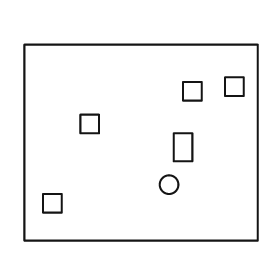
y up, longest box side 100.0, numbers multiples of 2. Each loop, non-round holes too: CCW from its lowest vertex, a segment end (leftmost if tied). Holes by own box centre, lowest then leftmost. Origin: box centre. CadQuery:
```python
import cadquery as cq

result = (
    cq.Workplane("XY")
    .moveTo(-50.0, -42.0)
    .lineTo(50.0, -42.0)
    .lineTo(50.0, 42.0)
    .lineTo(-50.0, 42.0)
    .close()
    .moveTo(-42.0, -30.0)
    .lineTo(-34.0, -30.0)
    .lineTo(-34.0, -22.0)
    .lineTo(-42.0, -22.0)
    .close()
    .moveTo(12.0, -18.0)
    .circle(4.0)
    .moveTo(14.0, -8.0)
    .lineTo(22.0, -8.0)
    .lineTo(22.0, 4.0)
    .lineTo(14.0, 4.0)
    .close()
    .moveTo(-26.0, 4.0)
    .lineTo(-18.0, 4.0)
    .lineTo(-18.0, 12.0)
    .lineTo(-26.0, 12.0)
    .close()
    .moveTo(18.0, 18.0)
    .lineTo(26.0, 18.0)
    .lineTo(26.0, 26.0)
    .lineTo(18.0, 26.0)
    .close()
    .moveTo(36.0, 20.0)
    .lineTo(44.0, 20.0)
    .lineTo(44.0, 28.0)
    .lineTo(36.0, 28.0)
    .close()
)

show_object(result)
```